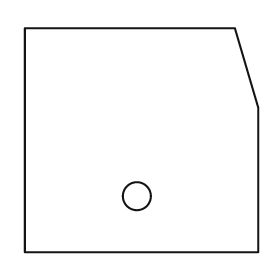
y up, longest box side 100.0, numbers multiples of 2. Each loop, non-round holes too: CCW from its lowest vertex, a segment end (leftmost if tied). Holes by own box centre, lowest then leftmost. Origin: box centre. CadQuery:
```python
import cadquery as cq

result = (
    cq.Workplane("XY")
    .moveTo(-50.0, -48.0)
    .lineTo(50.0, -48.0)
    .lineTo(50.0, 14.0)
    .lineTo(40.0, 48.0)
    .lineTo(-50.0, 48.0)
    .close()
    .moveTo(-2.0, -24.0)
    .circle(6.0)
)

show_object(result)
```